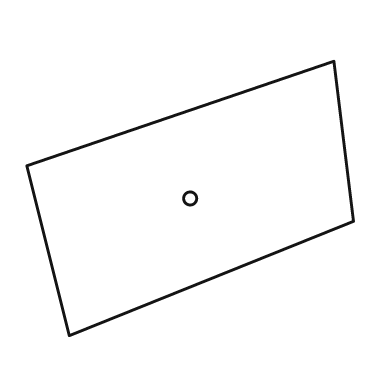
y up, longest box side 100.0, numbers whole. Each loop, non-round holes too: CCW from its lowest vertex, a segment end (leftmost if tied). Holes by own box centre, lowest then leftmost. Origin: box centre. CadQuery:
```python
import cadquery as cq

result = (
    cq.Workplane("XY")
    .moveTo(-37.0, -42.0)
    .lineTo(50.0, -7.0)
    .lineTo(44.0, 42.0)
    .lineTo(-50.0, 10.0)
    .close()
    .moveTo(0.0, 0.0)
    .circle(2.0)
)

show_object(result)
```